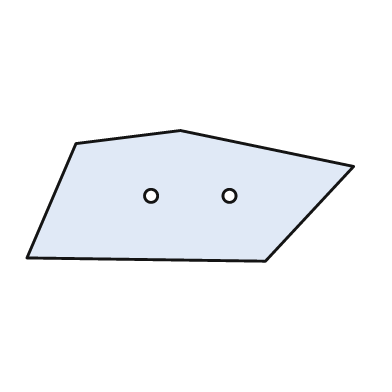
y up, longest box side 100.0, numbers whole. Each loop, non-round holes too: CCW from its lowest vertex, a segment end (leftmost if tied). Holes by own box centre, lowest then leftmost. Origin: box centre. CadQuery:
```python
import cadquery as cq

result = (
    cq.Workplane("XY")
    .moveTo(23.0, -20.0)
    .lineTo(50.0, 9.0)
    .lineTo(-3.0, 20.0)
    .lineTo(-35.0, 16.0)
    .lineTo(-50.0, -19.0)
    .close()
    .moveTo(-12.0, 0.0)
    .circle(2.0)
    .moveTo(12.0, 0.0)
    .circle(2.0)
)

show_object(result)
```